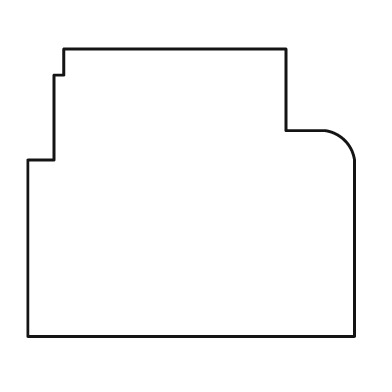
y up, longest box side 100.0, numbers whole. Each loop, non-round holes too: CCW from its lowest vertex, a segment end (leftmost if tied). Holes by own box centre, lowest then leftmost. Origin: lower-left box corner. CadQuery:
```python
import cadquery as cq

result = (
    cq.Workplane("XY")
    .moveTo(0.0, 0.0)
    .lineTo(100.0, 0.0)
    .lineTo(100.0, 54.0)
    .threePointArc((97.0, 60.0), (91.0, 63.0))
    .lineTo(79.0, 63.0)
    .lineTo(79.0, 88.0)
    .lineTo(11.0, 88.0)
    .lineTo(11.0, 80.0)
    .lineTo(8.0, 80.0)
    .lineTo(8.0, 54.0)
    .lineTo(0.0, 54.0)
    .close()
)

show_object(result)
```